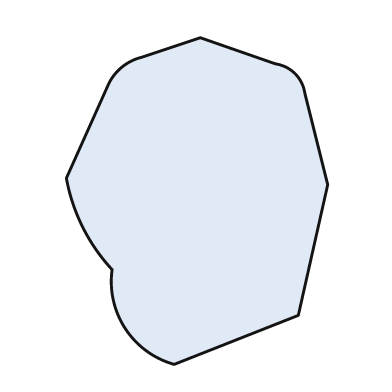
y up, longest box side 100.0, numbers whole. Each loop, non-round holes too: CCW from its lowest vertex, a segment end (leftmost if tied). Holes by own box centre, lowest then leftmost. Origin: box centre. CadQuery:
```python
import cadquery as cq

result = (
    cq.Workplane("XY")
    .moveTo(-7.0, -50.0)
    .lineTo(31.0, -35.0)
    .lineTo(40.0, 5.0)
    .lineTo(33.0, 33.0)
    .threePointArc((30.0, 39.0), (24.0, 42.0))
    .lineTo(1.0, 50.0)
    .lineTo(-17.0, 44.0)
    .threePointArc((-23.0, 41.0), (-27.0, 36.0))
    .lineTo(-40.0, 7.0)
    .threePointArc((-35.0, -8.0), (-26.0, -21.0))
    .threePointArc((-22.0, -39.0), (-7.0, -50.0))
    .close()
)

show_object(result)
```